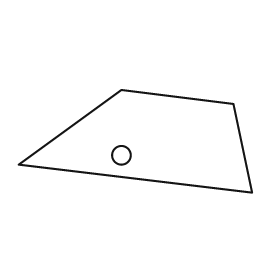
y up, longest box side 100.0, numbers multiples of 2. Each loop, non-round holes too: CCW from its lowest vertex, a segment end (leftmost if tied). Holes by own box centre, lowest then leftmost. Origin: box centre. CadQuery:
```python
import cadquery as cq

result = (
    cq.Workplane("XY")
    .moveTo(50.0, -22.0)
    .lineTo(42.0, 16.0)
    .lineTo(-6.0, 22.0)
    .lineTo(-50.0, -10.0)
    .close()
    .moveTo(-6.0, -6.0)
    .circle(4.0)
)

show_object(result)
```